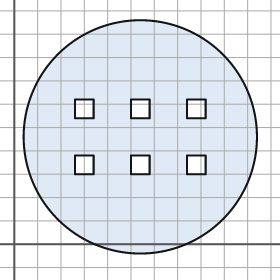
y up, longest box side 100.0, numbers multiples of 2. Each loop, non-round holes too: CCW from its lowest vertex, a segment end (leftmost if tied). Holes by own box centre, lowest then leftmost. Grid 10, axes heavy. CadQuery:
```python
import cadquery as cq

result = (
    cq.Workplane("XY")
    .moveTo(54.0, 46.0)
    .circle(50.0)
    .moveTo(26.0, 30.0)
    .lineTo(34.0, 30.0)
    .lineTo(34.0, 38.0)
    .lineTo(26.0, 38.0)
    .close()
    .moveTo(50.0, 30.0)
    .lineTo(58.0, 30.0)
    .lineTo(58.0, 38.0)
    .lineTo(50.0, 38.0)
    .close()
    .moveTo(74.0, 30.0)
    .lineTo(82.0, 30.0)
    .lineTo(82.0, 38.0)
    .lineTo(74.0, 38.0)
    .close()
    .moveTo(26.0, 54.0)
    .lineTo(34.0, 54.0)
    .lineTo(34.0, 62.0)
    .lineTo(26.0, 62.0)
    .close()
    .moveTo(50.0, 54.0)
    .lineTo(58.0, 54.0)
    .lineTo(58.0, 62.0)
    .lineTo(50.0, 62.0)
    .close()
    .moveTo(74.0, 54.0)
    .lineTo(82.0, 54.0)
    .lineTo(82.0, 62.0)
    .lineTo(74.0, 62.0)
    .close()
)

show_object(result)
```